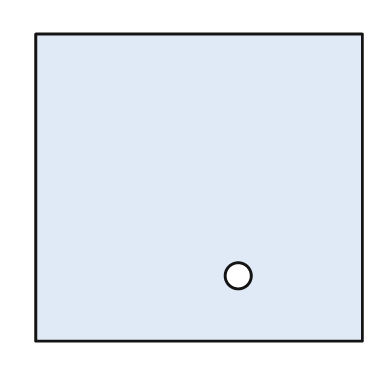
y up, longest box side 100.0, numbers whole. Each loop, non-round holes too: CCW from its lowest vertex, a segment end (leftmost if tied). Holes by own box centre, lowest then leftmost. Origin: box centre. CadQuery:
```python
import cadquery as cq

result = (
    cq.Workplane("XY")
    .moveTo(-50.0, -47.0)
    .lineTo(50.0, -47.0)
    .lineTo(50.0, 47.0)
    .lineTo(-50.0, 47.0)
    .close()
    .moveTo(12.0, -27.0)
    .circle(4.0)
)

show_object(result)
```